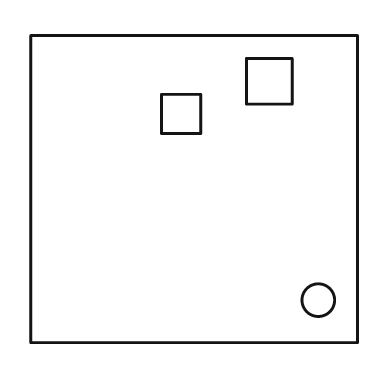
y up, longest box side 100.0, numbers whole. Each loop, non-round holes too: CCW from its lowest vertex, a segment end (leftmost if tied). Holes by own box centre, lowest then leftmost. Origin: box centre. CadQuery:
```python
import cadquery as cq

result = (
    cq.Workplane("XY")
    .moveTo(-50.0, -47.0)
    .lineTo(50.0, -47.0)
    .lineTo(50.0, 47.0)
    .lineTo(-50.0, 47.0)
    .close()
    .moveTo(38.0, -34.0)
    .circle(5.0)
    .moveTo(-10.0, 17.0)
    .lineTo(2.0, 17.0)
    .lineTo(2.0, 29.0)
    .lineTo(-10.0, 29.0)
    .close()
    .moveTo(16.0, 26.0)
    .lineTo(30.0, 26.0)
    .lineTo(30.0, 40.0)
    .lineTo(16.0, 40.0)
    .close()
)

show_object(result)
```